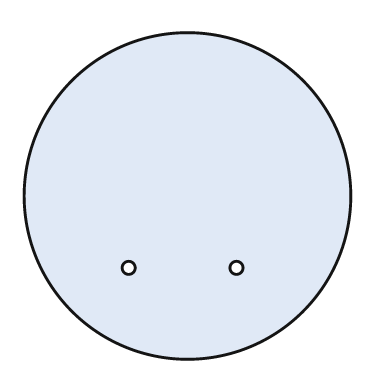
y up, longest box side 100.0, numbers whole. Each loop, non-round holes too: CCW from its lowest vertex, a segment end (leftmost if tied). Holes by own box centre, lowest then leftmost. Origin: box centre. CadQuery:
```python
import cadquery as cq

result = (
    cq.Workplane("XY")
    .moveTo(0.0, 0.0)
    .circle(50.0)
    .moveTo(-18.0, -22.0)
    .circle(2.0)
    .moveTo(15.0, -22.0)
    .circle(2.0)
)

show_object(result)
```